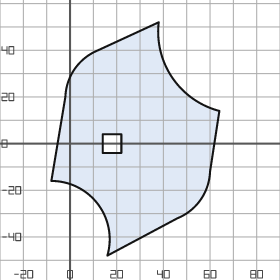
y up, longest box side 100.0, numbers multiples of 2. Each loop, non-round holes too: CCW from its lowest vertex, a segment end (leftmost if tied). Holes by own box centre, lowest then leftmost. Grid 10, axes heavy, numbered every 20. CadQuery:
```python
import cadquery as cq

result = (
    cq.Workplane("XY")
    .moveTo(16.0, -48.0)
    .lineTo(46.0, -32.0)
    .threePointArc((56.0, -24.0), (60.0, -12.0))
    .lineTo(64.0, 14.0)
    .threePointArc((44.0, 28.0), (38.0, 52.0))
    .lineTo(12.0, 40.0)
    .threePointArc((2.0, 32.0), (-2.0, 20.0))
    .lineTo(-8.0, -16.0)
    .threePointArc((12.0, -26.0), (16.0, -48.0))
    .close()
    .moveTo(14.0, -4.0)
    .lineTo(22.0, -4.0)
    .lineTo(22.0, 4.0)
    .lineTo(14.0, 4.0)
    .close()
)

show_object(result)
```